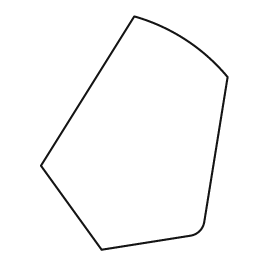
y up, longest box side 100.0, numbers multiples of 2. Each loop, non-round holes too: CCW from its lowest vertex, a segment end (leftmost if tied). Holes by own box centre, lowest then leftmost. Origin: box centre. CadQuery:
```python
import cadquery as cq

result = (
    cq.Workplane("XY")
    .moveTo(-14.0, -50.0)
    .lineTo(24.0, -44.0)
    .threePointArc((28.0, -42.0), (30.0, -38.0))
    .lineTo(40.0, 24.0)
    .threePointArc((22.0, 40.0), (0.0, 50.0))
    .lineTo(-40.0, -14.0)
    .close()
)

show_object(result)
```